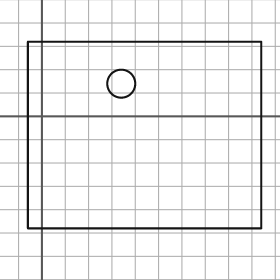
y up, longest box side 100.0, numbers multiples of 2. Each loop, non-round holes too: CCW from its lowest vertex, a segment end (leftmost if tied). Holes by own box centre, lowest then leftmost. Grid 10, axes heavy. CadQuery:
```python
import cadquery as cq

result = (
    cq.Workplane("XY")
    .moveTo(-6.0, -48.0)
    .lineTo(94.0, -48.0)
    .lineTo(94.0, 32.0)
    .lineTo(-6.0, 32.0)
    .close()
    .moveTo(34.0, 14.0)
    .circle(6.0)
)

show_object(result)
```